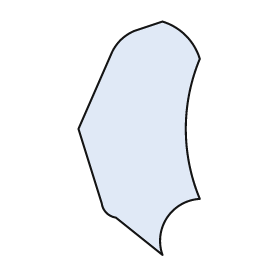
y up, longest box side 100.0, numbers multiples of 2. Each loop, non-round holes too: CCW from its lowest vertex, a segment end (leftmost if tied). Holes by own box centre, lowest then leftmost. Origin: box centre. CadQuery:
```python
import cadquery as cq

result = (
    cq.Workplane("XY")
    .moveTo(10.0, -50.0)
    .threePointArc((12.0, -34.0), (26.0, -26.0))
    .threePointArc((20.0, 4.0), (26.0, 34.0))
    .threePointArc((20.0, 44.0), (10.0, 50.0))
    .lineTo(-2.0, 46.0)
    .threePointArc((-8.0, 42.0), (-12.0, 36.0))
    .lineTo(-26.0, 4.0)
    .lineTo(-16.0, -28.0)
    .threePointArc((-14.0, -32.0), (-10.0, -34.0))
    .close()
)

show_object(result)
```